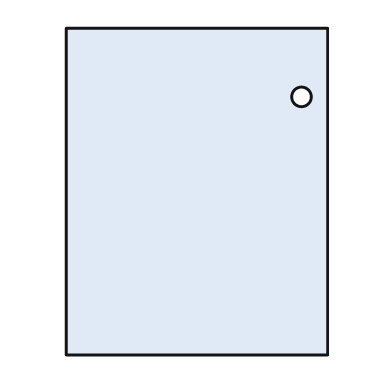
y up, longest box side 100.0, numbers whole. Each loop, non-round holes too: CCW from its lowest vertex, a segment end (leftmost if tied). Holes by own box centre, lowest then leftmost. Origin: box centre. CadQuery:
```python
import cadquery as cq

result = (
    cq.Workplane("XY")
    .moveTo(-40.0, -50.0)
    .lineTo(40.0, -50.0)
    .lineTo(40.0, 50.0)
    .lineTo(-40.0, 50.0)
    .close()
    .moveTo(32.0, 29.0)
    .circle(3.0)
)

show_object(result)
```